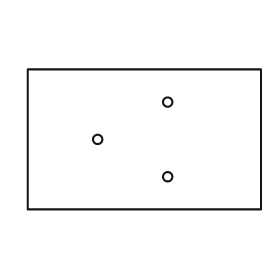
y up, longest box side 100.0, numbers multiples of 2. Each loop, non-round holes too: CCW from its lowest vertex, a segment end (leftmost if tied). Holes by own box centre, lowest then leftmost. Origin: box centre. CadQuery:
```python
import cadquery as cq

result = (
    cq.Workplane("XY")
    .moveTo(-50.0, -30.0)
    .lineTo(50.0, -30.0)
    .lineTo(50.0, 30.0)
    .lineTo(-50.0, 30.0)
    .close()
    .moveTo(10.0, -16.0)
    .circle(2.0)
    .moveTo(-20.0, 0.0)
    .circle(2.0)
    .moveTo(10.0, 16.0)
    .circle(2.0)
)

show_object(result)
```